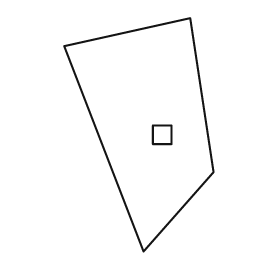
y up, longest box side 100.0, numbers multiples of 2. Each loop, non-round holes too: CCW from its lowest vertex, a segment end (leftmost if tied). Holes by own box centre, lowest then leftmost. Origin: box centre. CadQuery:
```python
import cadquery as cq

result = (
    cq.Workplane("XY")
    .moveTo(2.0, -50.0)
    .lineTo(32.0, -16.0)
    .lineTo(22.0, 50.0)
    .lineTo(-32.0, 38.0)
    .close()
    .moveTo(6.0, -4.0)
    .lineTo(14.0, -4.0)
    .lineTo(14.0, 4.0)
    .lineTo(6.0, 4.0)
    .close()
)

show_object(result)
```